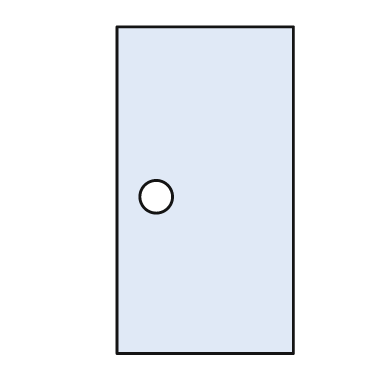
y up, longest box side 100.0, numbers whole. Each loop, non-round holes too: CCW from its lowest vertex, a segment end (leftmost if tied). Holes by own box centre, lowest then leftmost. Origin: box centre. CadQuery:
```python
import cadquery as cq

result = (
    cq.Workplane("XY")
    .moveTo(-27.0, -50.0)
    .lineTo(27.0, -50.0)
    .lineTo(27.0, 50.0)
    .lineTo(-27.0, 50.0)
    .close()
    .moveTo(-15.0, -2.0)
    .circle(5.0)
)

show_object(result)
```